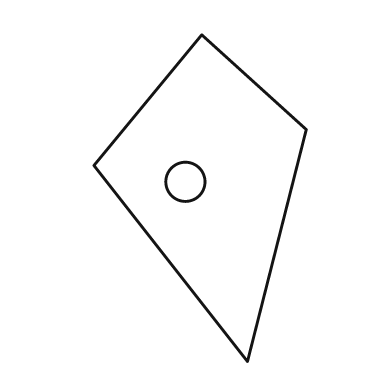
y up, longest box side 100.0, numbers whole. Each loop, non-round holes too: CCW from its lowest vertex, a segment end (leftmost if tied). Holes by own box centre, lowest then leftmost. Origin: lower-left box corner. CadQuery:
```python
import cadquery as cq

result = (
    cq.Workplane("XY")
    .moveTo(47.0, 0.0)
    .lineTo(65.0, 71.0)
    .lineTo(33.0, 100.0)
    .lineTo(0.0, 60.0)
    .close()
    .moveTo(28.0, 55.0)
    .circle(6.0)
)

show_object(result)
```